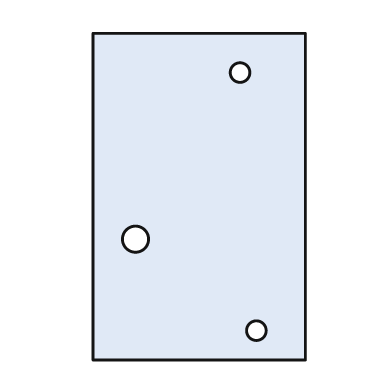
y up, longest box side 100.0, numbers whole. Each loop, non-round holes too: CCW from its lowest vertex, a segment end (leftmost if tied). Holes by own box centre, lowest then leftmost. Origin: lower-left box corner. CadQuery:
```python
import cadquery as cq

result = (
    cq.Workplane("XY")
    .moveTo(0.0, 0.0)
    .lineTo(65.0, 0.0)
    .lineTo(65.0, 100.0)
    .lineTo(0.0, 100.0)
    .close()
    .moveTo(50.0, 9.0)
    .circle(3.0)
    .moveTo(13.0, 37.0)
    .circle(4.0)
    .moveTo(45.0, 88.0)
    .circle(3.0)
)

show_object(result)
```